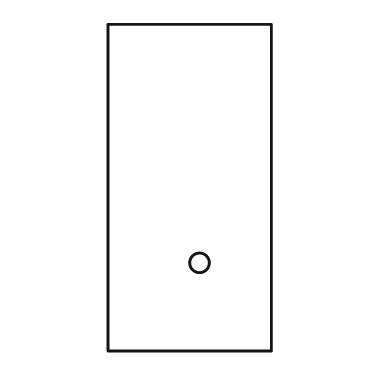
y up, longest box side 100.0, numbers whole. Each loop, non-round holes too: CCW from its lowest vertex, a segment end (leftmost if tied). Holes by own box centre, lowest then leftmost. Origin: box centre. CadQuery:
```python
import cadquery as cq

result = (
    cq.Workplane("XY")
    .moveTo(-25.0, -50.0)
    .lineTo(25.0, -50.0)
    .lineTo(25.0, 50.0)
    .lineTo(-25.0, 50.0)
    .close()
    .moveTo(3.0, -23.0)
    .circle(3.0)
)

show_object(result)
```